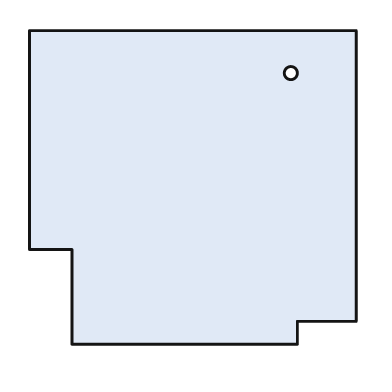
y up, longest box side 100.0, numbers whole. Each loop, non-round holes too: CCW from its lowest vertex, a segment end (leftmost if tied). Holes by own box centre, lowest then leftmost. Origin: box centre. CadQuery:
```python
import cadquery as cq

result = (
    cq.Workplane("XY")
    .moveTo(-37.0, -48.0)
    .lineTo(32.0, -48.0)
    .lineTo(32.0, -41.0)
    .lineTo(50.0, -41.0)
    .lineTo(50.0, 48.0)
    .lineTo(-50.0, 48.0)
    .lineTo(-50.0, -19.0)
    .lineTo(-37.0, -19.0)
    .close()
    .moveTo(30.0, 35.0)
    .circle(2.0)
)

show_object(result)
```